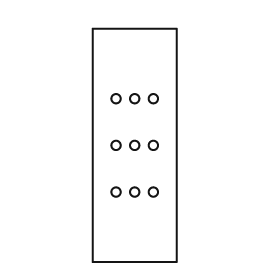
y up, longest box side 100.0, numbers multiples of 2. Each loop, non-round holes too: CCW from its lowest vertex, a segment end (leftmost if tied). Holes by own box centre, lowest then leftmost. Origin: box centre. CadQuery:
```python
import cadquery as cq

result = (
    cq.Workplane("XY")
    .moveTo(-18.0, -50.0)
    .lineTo(18.0, -50.0)
    .lineTo(18.0, 50.0)
    .lineTo(-18.0, 50.0)
    .close()
    .moveTo(-8.0, -20.0)
    .circle(2.0)
    .moveTo(0.0, -20.0)
    .circle(2.0)
    .moveTo(8.0, -20.0)
    .circle(2.0)
    .moveTo(-8.0, 0.0)
    .circle(2.0)
    .moveTo(0.0, 0.0)
    .circle(2.0)
    .moveTo(8.0, 0.0)
    .circle(2.0)
    .moveTo(-8.0, 20.0)
    .circle(2.0)
    .moveTo(0.0, 20.0)
    .circle(2.0)
    .moveTo(8.0, 20.0)
    .circle(2.0)
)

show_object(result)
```